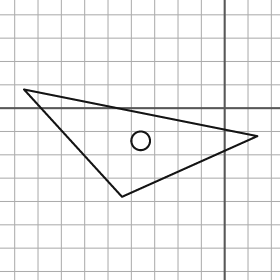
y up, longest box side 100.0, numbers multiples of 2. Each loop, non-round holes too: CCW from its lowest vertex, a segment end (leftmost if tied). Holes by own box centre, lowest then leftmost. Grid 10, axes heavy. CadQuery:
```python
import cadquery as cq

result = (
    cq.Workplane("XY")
    .moveTo(-44.0, -38.0)
    .lineTo(14.0, -12.0)
    .lineTo(-86.0, 8.0)
    .close()
    .moveTo(-36.0, -14.0)
    .circle(4.0)
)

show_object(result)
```